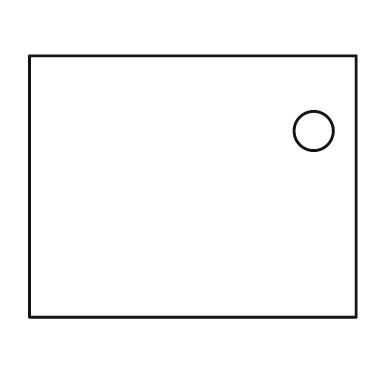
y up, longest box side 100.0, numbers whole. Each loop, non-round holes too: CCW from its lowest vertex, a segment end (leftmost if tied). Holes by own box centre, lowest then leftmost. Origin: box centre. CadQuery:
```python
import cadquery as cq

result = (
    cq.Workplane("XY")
    .moveTo(-50.0, -40.0)
    .lineTo(50.0, -40.0)
    .lineTo(50.0, 40.0)
    .lineTo(-50.0, 40.0)
    .close()
    .moveTo(37.0, 17.0)
    .circle(6.0)
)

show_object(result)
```